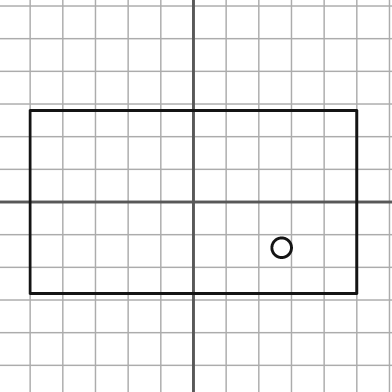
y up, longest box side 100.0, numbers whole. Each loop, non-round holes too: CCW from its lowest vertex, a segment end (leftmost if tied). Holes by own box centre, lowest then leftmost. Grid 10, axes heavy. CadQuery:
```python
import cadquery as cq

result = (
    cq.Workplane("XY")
    .moveTo(-50.0, -28.0)
    .lineTo(50.0, -28.0)
    .lineTo(50.0, 28.0)
    .lineTo(-50.0, 28.0)
    .close()
    .moveTo(27.0, -14.0)
    .circle(3.0)
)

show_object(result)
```